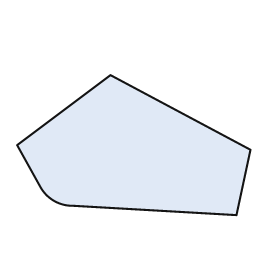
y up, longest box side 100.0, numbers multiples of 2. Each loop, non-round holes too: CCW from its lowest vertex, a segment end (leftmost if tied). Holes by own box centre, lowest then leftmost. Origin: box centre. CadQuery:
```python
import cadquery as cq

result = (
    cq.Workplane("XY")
    .moveTo(44.0, -30.0)
    .lineTo(50.0, -2.0)
    .lineTo(-10.0, 30.0)
    .lineTo(-50.0, 0.0)
    .lineTo(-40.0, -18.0)
    .threePointArc((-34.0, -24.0), (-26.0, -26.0))
    .close()
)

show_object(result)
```